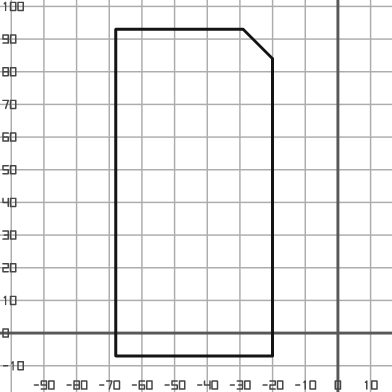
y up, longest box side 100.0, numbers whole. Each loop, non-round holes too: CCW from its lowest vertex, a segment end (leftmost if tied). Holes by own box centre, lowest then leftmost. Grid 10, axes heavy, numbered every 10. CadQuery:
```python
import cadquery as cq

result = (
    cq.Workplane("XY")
    .moveTo(-68.0, -7.0)
    .lineTo(-20.0, -7.0)
    .lineTo(-20.0, 84.0)
    .lineTo(-29.0, 93.0)
    .lineTo(-68.0, 93.0)
    .close()
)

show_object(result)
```